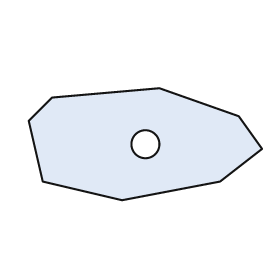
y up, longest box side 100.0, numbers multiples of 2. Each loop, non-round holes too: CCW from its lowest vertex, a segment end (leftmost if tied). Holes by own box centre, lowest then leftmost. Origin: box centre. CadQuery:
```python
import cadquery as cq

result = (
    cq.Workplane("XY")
    .moveTo(-10.0, -24.0)
    .lineTo(32.0, -16.0)
    .lineTo(50.0, -2.0)
    .lineTo(40.0, 12.0)
    .lineTo(6.0, 24.0)
    .lineTo(-40.0, 20.0)
    .lineTo(-50.0, 10.0)
    .lineTo(-44.0, -16.0)
    .close()
    .moveTo(0.0, 0.0)
    .circle(6.0)
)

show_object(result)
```